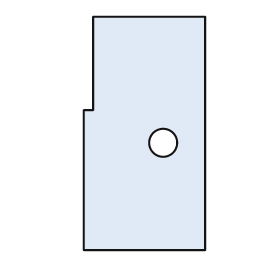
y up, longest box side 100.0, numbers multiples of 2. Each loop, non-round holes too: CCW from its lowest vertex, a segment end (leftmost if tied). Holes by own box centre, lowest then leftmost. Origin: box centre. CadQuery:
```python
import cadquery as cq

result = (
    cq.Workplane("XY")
    .moveTo(-26.0, -50.0)
    .lineTo(26.0, -50.0)
    .lineTo(26.0, 50.0)
    .lineTo(-22.0, 50.0)
    .lineTo(-22.0, 10.0)
    .lineTo(-26.0, 10.0)
    .close()
    .moveTo(8.0, -4.0)
    .circle(6.0)
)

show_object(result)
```